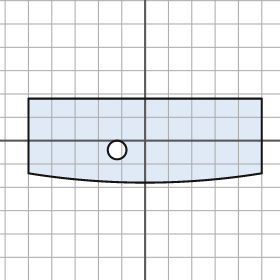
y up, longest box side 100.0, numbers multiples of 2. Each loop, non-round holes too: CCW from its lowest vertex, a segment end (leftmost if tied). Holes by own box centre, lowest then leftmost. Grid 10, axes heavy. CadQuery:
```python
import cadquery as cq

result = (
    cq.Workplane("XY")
    .moveTo(-50.0, -14.0)
    .threePointArc((0.0, -18.0), (50.0, -14.0))
    .lineTo(50.0, 18.0)
    .lineTo(-50.0, 18.0)
    .close()
    .moveTo(-12.0, -4.0)
    .circle(4.0)
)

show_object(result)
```